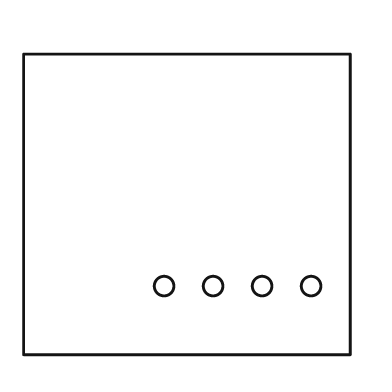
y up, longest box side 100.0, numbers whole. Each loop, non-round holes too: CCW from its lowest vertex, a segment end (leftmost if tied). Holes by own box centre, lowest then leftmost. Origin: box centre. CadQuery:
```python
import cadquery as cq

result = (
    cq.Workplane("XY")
    .moveTo(-50.0, -46.0)
    .lineTo(50.0, -46.0)
    .lineTo(50.0, 46.0)
    .lineTo(-50.0, 46.0)
    .close()
    .moveTo(-7.0, -25.0)
    .circle(3.0)
    .moveTo(8.0, -25.0)
    .circle(3.0)
    .moveTo(23.0, -25.0)
    .circle(3.0)
    .moveTo(38.0, -25.0)
    .circle(3.0)
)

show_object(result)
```